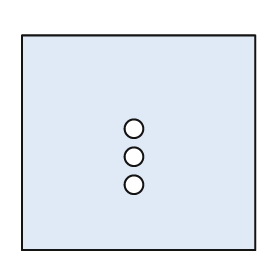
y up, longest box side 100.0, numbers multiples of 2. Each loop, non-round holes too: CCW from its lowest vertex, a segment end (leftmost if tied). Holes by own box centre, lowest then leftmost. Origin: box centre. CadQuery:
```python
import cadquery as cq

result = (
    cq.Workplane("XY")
    .moveTo(-50.0, -46.0)
    .lineTo(50.0, -46.0)
    .lineTo(50.0, 46.0)
    .lineTo(-50.0, 46.0)
    .close()
    .moveTo(-2.0, -18.0)
    .circle(4.0)
    .moveTo(-2.0, -6.0)
    .circle(4.0)
    .moveTo(-2.0, 6.0)
    .circle(4.0)
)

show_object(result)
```